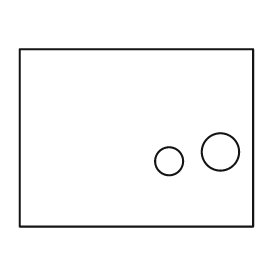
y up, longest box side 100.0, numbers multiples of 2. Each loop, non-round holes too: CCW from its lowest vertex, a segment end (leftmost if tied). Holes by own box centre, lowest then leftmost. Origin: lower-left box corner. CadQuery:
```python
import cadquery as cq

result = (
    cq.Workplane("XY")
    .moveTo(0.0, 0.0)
    .lineTo(100.0, 0.0)
    .lineTo(100.0, 76.0)
    .lineTo(0.0, 76.0)
    .close()
    .moveTo(64.0, 28.0)
    .circle(6.0)
    .moveTo(86.0, 32.0)
    .circle(8.0)
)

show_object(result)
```